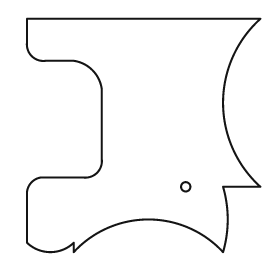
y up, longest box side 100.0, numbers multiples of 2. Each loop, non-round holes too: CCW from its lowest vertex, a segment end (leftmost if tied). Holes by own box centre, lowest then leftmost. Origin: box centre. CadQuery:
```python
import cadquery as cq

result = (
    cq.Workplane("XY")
    .moveTo(-30.0, -50.0)
    .threePointArc((2.0, -36.0), (34.0, -50.0))
    .threePointArc((36.0, -36.0), (34.0, -22.0))
    .lineTo(50.0, -22.0)
    .threePointArc((34.0, 14.0), (50.0, 50.0))
    .lineTo(-50.0, 50.0)
    .lineTo(-50.0, 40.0)
    .threePointArc((-48.0, 34.0), (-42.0, 32.0))
    .lineTo(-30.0, 32.0)
    .threePointArc((-22.0, 28.0), (-18.0, 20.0))
    .lineTo(-18.0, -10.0)
    .threePointArc((-20.0, -16.0), (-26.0, -18.0))
    .lineTo(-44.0, -18.0)
    .threePointArc((-48.0, -20.0), (-50.0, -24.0))
    .lineTo(-50.0, -46.0)
    .threePointArc((-40.0, -50.0), (-30.0, -46.0))
    .close()
    .moveTo(18.0, -22.0)
    .circle(2.0)
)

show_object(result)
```